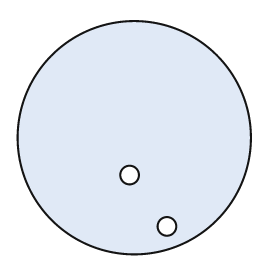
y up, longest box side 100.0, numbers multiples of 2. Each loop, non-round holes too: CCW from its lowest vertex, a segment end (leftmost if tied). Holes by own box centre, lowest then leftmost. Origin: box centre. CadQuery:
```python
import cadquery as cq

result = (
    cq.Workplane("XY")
    .moveTo(0.0, 0.0)
    .circle(50.0)
    .moveTo(14.0, -38.0)
    .circle(4.0)
    .moveTo(-2.0, -16.0)
    .circle(4.0)
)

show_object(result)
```